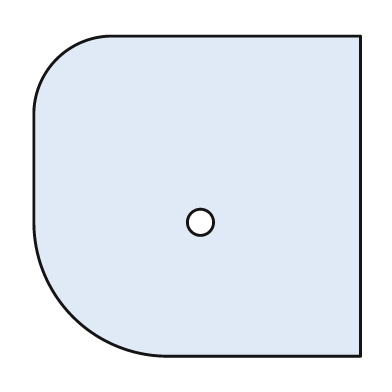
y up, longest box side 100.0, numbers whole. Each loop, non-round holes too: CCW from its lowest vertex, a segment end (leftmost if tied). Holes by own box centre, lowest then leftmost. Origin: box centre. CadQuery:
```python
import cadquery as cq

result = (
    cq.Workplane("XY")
    .moveTo(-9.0, -49.0)
    .lineTo(50.0, -49.0)
    .lineTo(50.0, 49.0)
    .lineTo(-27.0, 49.0)
    .threePointArc((-43.0, 42.0), (-50.0, 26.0))
    .lineTo(-50.0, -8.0)
    .threePointArc((-38.0, -37.0), (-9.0, -49.0))
    .close()
    .moveTo(1.0, -8.0)
    .circle(4.0)
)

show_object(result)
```